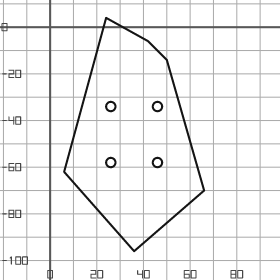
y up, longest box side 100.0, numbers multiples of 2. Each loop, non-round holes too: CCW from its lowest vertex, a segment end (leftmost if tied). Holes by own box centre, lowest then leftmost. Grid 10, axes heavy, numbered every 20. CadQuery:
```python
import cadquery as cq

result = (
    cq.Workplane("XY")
    .moveTo(36.0, -96.0)
    .lineTo(66.0, -70.0)
    .lineTo(50.0, -14.0)
    .lineTo(42.0, -6.0)
    .lineTo(24.0, 4.0)
    .lineTo(6.0, -62.0)
    .close()
    .moveTo(26.0, -58.0)
    .circle(2.0)
    .moveTo(46.0, -58.0)
    .circle(2.0)
    .moveTo(26.0, -34.0)
    .circle(2.0)
    .moveTo(46.0, -34.0)
    .circle(2.0)
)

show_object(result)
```